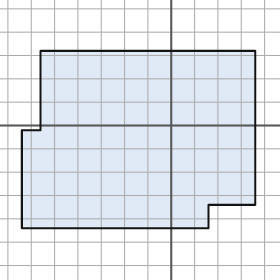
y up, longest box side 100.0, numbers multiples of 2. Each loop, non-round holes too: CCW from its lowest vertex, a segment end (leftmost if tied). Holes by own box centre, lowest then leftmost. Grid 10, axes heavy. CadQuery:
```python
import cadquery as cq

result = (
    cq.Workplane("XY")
    .moveTo(-64.0, -44.0)
    .lineTo(16.0, -44.0)
    .lineTo(16.0, -34.0)
    .lineTo(36.0, -34.0)
    .lineTo(36.0, 32.0)
    .lineTo(-56.0, 32.0)
    .lineTo(-56.0, -2.0)
    .lineTo(-64.0, -2.0)
    .close()
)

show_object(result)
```